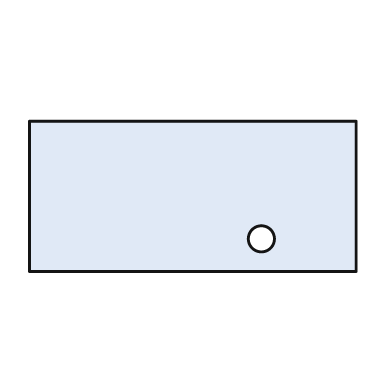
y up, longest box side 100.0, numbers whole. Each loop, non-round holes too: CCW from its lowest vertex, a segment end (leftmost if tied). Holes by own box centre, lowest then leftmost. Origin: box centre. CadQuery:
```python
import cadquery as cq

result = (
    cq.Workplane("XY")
    .moveTo(-50.0, -23.0)
    .lineTo(50.0, -23.0)
    .lineTo(50.0, 23.0)
    .lineTo(-50.0, 23.0)
    .close()
    .moveTo(21.0, -13.0)
    .circle(4.0)
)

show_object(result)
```